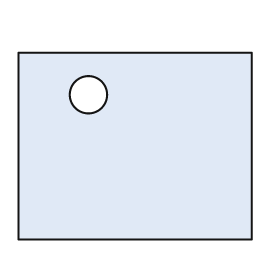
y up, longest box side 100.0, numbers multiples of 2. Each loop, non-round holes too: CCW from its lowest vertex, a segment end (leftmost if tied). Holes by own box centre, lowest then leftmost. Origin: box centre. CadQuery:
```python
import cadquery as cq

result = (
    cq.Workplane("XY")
    .moveTo(-50.0, -40.0)
    .lineTo(50.0, -40.0)
    .lineTo(50.0, 40.0)
    .lineTo(-50.0, 40.0)
    .close()
    .moveTo(-20.0, 22.0)
    .circle(8.0)
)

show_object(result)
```